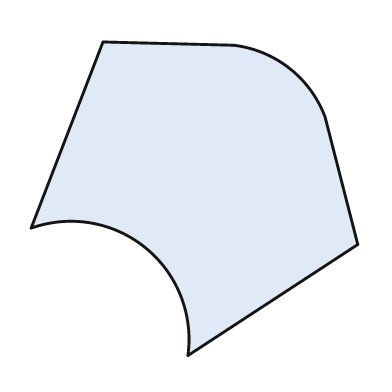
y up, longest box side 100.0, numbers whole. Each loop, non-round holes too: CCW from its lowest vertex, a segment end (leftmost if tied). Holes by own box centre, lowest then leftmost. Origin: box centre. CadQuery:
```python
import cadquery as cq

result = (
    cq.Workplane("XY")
    .moveTo(-2.0, -48.0)
    .lineTo(50.0, -14.0)
    .lineTo(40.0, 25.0)
    .threePointArc((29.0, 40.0), (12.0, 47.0))
    .lineTo(-28.0, 48.0)
    .lineTo(-50.0, -9.0)
    .threePointArc((-15.0, -15.0), (-2.0, -48.0))
    .close()
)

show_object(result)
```